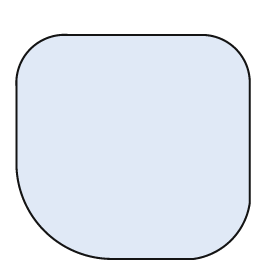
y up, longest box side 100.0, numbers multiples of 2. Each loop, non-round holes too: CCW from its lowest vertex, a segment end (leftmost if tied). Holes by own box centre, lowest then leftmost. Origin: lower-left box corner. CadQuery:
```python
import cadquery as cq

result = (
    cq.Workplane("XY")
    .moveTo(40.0, 0.0)
    .lineTo(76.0, 0.0)
    .threePointArc((92.0, 8.0), (100.0, 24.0))
    .lineTo(100.0, 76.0)
    .threePointArc((94.0, 90.0), (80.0, 96.0))
    .lineTo(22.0, 96.0)
    .threePointArc((6.0, 90.0), (0.0, 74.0))
    .lineTo(0.0, 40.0)
    .threePointArc((12.0, 12.0), (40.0, 0.0))
    .close()
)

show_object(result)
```